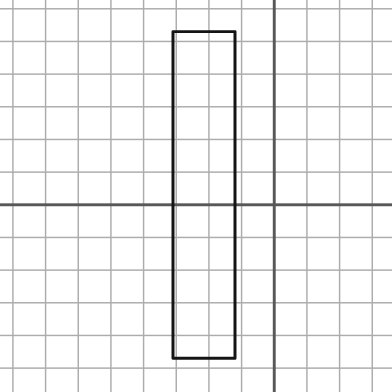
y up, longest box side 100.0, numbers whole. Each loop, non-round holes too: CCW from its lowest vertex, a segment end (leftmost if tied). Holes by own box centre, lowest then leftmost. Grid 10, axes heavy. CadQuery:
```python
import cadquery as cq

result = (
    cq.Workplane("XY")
    .moveTo(-31.0, -47.0)
    .lineTo(-12.0, -47.0)
    .lineTo(-12.0, 53.0)
    .lineTo(-31.0, 53.0)
    .close()
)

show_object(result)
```